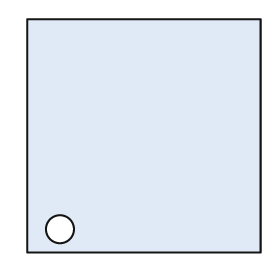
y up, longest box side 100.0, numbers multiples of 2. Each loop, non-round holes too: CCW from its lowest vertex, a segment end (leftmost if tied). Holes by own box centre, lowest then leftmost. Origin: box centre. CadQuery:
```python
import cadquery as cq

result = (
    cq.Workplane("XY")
    .moveTo(-50.0, -50.0)
    .lineTo(50.0, -50.0)
    .lineTo(50.0, 50.0)
    .lineTo(-50.0, 50.0)
    .close()
    .moveTo(-36.0, -40.0)
    .circle(6.0)
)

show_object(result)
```